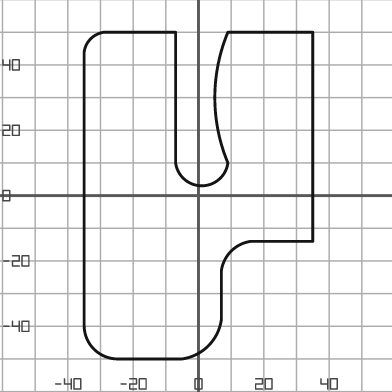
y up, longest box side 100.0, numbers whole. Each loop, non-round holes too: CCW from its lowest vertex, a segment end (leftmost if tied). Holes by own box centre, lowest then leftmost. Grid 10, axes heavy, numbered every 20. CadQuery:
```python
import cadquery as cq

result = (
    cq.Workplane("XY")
    .moveTo(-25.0, -50.0)
    .lineTo(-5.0, -50.0)
    .threePointArc((3.0, -46.0), (7.0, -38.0))
    .lineTo(7.0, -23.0)
    .threePointArc((10.0, -17.0), (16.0, -14.0))
    .lineTo(35.0, -14.0)
    .lineTo(35.0, 50.0)
    .lineTo(9.0, 50.0)
    .threePointArc((5.0, 30.0), (9.0, 10.0))
    .threePointArc((1.0, 3.0), (-7.0, 10.0))
    .lineTo(-7.0, 50.0)
    .lineTo(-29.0, 50.0)
    .threePointArc((-33.0, 48.0), (-35.0, 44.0))
    .lineTo(-35.0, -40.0)
    .threePointArc((-32.0, -47.0), (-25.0, -50.0))
    .close()
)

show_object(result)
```